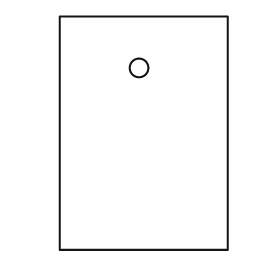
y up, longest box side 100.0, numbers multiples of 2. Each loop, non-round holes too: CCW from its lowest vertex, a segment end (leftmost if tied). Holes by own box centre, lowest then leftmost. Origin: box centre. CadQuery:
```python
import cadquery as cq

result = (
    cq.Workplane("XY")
    .moveTo(-36.0, -50.0)
    .lineTo(36.0, -50.0)
    .lineTo(36.0, 50.0)
    .lineTo(-36.0, 50.0)
    .close()
    .moveTo(-2.0, 28.0)
    .circle(4.0)
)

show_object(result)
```